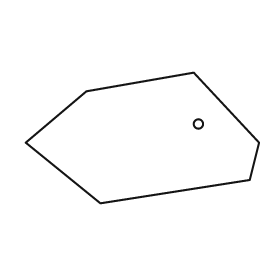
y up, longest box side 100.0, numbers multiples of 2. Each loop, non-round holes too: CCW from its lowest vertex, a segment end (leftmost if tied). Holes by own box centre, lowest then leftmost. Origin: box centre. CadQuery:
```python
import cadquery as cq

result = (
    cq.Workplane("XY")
    .moveTo(-18.0, -28.0)
    .lineTo(46.0, -18.0)
    .lineTo(50.0, -2.0)
    .lineTo(22.0, 28.0)
    .lineTo(-24.0, 20.0)
    .lineTo(-50.0, -2.0)
    .close()
    .moveTo(24.0, 6.0)
    .circle(2.0)
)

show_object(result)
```